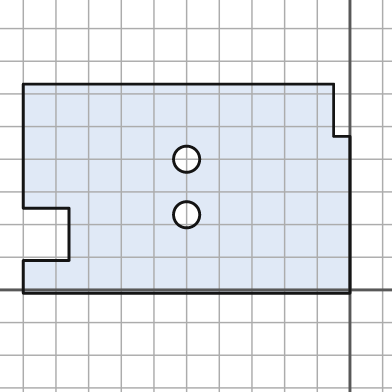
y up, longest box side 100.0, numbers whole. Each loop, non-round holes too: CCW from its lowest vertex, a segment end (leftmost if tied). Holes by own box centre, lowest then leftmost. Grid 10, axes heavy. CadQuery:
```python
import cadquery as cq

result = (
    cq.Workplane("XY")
    .moveTo(-100.0, -1.0)
    .lineTo(0.0, -1.0)
    .lineTo(0.0, 47.0)
    .lineTo(-5.0, 47.0)
    .lineTo(-5.0, 63.0)
    .lineTo(-100.0, 63.0)
    .lineTo(-100.0, 25.0)
    .lineTo(-86.0, 25.0)
    .lineTo(-86.0, 9.0)
    .lineTo(-100.0, 9.0)
    .close()
    .moveTo(-50.0, 23.0)
    .circle(4.0)
    .moveTo(-50.0, 40.0)
    .circle(4.0)
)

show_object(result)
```